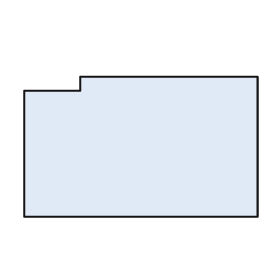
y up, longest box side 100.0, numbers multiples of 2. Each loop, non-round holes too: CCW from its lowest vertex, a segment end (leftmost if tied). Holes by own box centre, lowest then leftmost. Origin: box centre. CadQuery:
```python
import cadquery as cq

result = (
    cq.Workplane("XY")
    .moveTo(-50.0, -30.0)
    .lineTo(50.0, -30.0)
    .lineTo(50.0, 30.0)
    .lineTo(-26.0, 30.0)
    .lineTo(-26.0, 24.0)
    .lineTo(-50.0, 24.0)
    .close()
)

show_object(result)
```